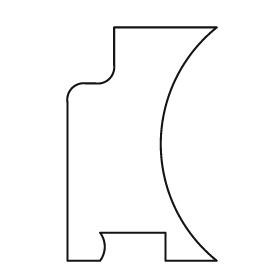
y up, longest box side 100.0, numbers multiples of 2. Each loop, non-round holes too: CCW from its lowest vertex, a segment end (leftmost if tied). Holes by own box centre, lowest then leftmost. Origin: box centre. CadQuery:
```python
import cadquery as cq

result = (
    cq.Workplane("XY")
    .moveTo(-32.0, -50.0)
    .lineTo(-18.0, -50.0)
    .threePointArc((-16.0, -44.0), (-18.0, -38.0))
    .lineTo(10.0, -38.0)
    .lineTo(10.0, -50.0)
    .lineTo(32.0, -50.0)
    .threePointArc((8.0, 0.0), (32.0, 50.0))
    .lineTo(-12.0, 50.0)
    .lineTo(-12.0, 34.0)
    .threePointArc((-14.0, 28.0), (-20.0, 26.0))
    .lineTo(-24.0, 26.0)
    .threePointArc((-30.0, 24.0), (-32.0, 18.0))
    .close()
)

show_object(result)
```